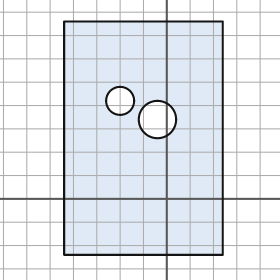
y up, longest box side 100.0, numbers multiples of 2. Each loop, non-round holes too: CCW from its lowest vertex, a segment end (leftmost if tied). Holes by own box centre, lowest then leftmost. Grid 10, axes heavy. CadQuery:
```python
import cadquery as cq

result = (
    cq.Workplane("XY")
    .moveTo(-44.0, -24.0)
    .lineTo(24.0, -24.0)
    .lineTo(24.0, 76.0)
    .lineTo(-44.0, 76.0)
    .close()
    .moveTo(-4.0, 34.0)
    .circle(8.0)
    .moveTo(-20.0, 42.0)
    .circle(6.0)
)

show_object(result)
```